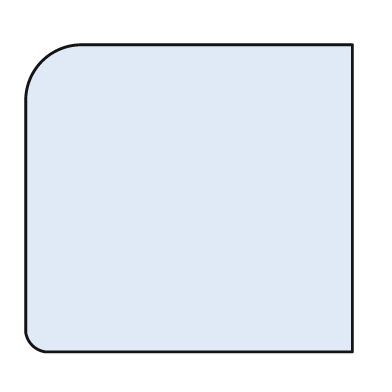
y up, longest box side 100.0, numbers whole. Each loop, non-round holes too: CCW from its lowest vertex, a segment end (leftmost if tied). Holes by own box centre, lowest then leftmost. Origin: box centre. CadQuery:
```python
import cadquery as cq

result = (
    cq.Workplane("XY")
    .moveTo(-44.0, -47.0)
    .lineTo(50.0, -47.0)
    .lineTo(50.0, 47.0)
    .lineTo(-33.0, 47.0)
    .threePointArc((-45.0, 42.0), (-50.0, 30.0))
    .lineTo(-50.0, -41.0)
    .threePointArc((-48.0, -45.0), (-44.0, -47.0))
    .close()
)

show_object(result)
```